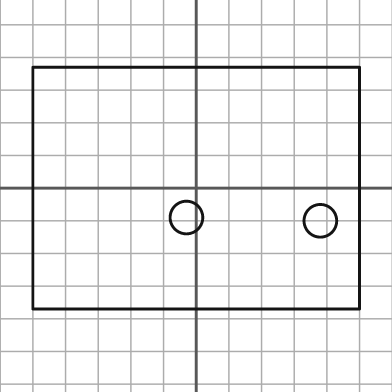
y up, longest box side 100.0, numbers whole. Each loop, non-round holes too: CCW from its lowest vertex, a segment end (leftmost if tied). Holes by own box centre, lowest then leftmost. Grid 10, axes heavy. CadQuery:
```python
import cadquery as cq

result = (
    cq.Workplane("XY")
    .moveTo(-50.0, -37.0)
    .lineTo(50.0, -37.0)
    .lineTo(50.0, 37.0)
    .lineTo(-50.0, 37.0)
    .close()
    .moveTo(38.0, -10.0)
    .circle(5.0)
    .moveTo(-3.0, -9.0)
    .circle(5.0)
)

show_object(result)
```